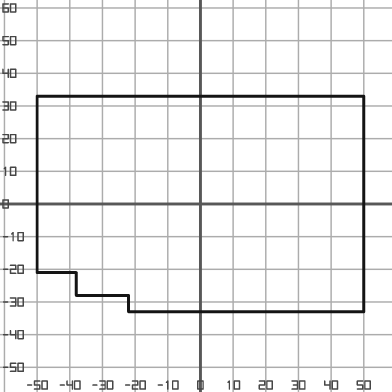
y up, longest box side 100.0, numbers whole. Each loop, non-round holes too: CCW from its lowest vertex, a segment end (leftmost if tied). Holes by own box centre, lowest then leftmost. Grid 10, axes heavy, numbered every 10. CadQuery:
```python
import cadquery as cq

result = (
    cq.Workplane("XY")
    .moveTo(-22.0, -33.0)
    .lineTo(50.0, -33.0)
    .lineTo(50.0, 33.0)
    .lineTo(-50.0, 33.0)
    .lineTo(-50.0, -21.0)
    .lineTo(-38.0, -21.0)
    .lineTo(-38.0, -28.0)
    .lineTo(-22.0, -28.0)
    .close()
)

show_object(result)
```